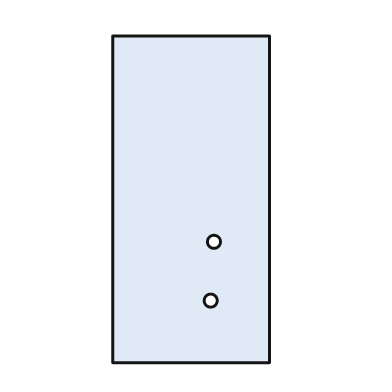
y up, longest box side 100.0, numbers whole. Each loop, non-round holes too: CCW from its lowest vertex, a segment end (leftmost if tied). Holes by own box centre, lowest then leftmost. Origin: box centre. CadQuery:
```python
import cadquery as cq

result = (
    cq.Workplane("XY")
    .moveTo(-24.0, -50.0)
    .lineTo(24.0, -50.0)
    .lineTo(24.0, 50.0)
    .lineTo(-24.0, 50.0)
    .close()
    .moveTo(6.0, -31.0)
    .circle(2.0)
    .moveTo(7.0, -13.0)
    .circle(2.0)
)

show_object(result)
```